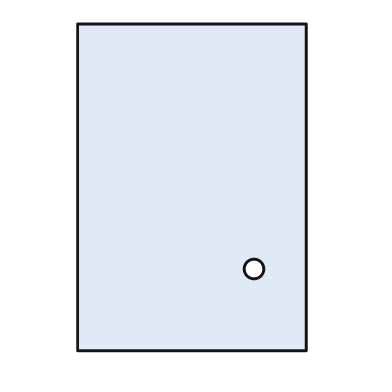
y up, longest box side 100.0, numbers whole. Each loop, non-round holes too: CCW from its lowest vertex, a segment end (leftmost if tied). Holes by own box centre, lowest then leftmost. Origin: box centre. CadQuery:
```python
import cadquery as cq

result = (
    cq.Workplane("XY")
    .moveTo(-35.0, -50.0)
    .lineTo(35.0, -50.0)
    .lineTo(35.0, 50.0)
    .lineTo(-35.0, 50.0)
    .close()
    .moveTo(19.0, -25.0)
    .circle(3.0)
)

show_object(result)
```